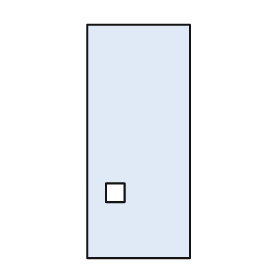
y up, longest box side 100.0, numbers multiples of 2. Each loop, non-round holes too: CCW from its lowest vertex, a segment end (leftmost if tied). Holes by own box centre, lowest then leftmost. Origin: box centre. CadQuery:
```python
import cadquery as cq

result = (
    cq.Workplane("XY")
    .moveTo(-22.0, -50.0)
    .lineTo(22.0, -50.0)
    .lineTo(22.0, 50.0)
    .lineTo(-22.0, 50.0)
    .close()
    .moveTo(-14.0, -26.0)
    .lineTo(-6.0, -26.0)
    .lineTo(-6.0, -18.0)
    .lineTo(-14.0, -18.0)
    .close()
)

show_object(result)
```